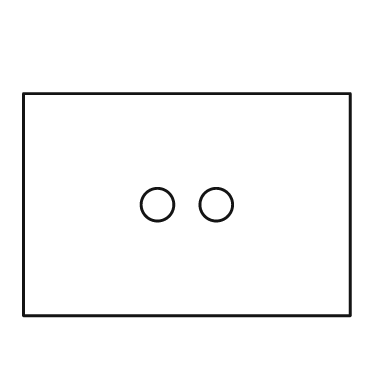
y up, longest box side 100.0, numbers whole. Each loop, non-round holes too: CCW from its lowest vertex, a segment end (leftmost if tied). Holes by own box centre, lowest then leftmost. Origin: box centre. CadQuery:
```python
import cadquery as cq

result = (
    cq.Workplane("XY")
    .moveTo(-50.0, -34.0)
    .lineTo(50.0, -34.0)
    .lineTo(50.0, 34.0)
    .lineTo(-50.0, 34.0)
    .close()
    .moveTo(-9.0, 0.0)
    .circle(5.0)
    .moveTo(9.0, 0.0)
    .circle(5.0)
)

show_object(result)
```